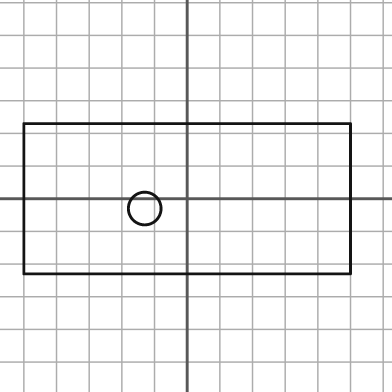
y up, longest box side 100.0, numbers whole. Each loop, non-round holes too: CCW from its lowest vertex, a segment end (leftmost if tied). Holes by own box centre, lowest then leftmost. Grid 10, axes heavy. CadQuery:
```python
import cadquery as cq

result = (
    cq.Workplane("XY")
    .moveTo(-50.0, -23.0)
    .lineTo(50.0, -23.0)
    .lineTo(50.0, 23.0)
    .lineTo(-50.0, 23.0)
    .close()
    .moveTo(-13.0, -3.0)
    .circle(5.0)
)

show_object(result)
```